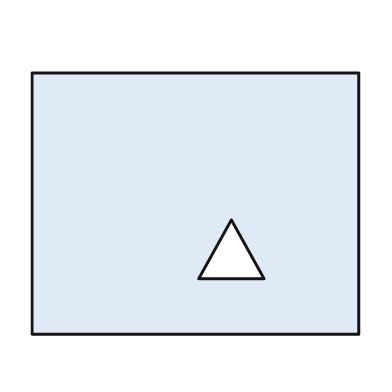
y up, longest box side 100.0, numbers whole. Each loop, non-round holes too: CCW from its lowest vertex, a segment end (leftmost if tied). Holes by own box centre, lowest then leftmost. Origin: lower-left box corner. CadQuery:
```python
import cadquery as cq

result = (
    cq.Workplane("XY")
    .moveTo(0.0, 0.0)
    .lineTo(100.0, 0.0)
    .lineTo(100.0, 80.0)
    .lineTo(0.0, 80.0)
    .close()
    .moveTo(51.0, 17.0)
    .lineTo(71.0, 17.0)
    .lineTo(61.0, 35.0)
    .close()
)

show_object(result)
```